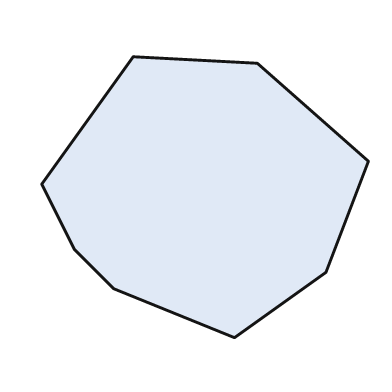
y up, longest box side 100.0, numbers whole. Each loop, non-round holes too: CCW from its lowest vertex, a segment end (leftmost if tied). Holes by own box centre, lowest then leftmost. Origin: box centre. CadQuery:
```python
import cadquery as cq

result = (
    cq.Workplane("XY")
    .moveTo(9.0, -43.0)
    .lineTo(37.0, -23.0)
    .lineTo(50.0, 11.0)
    .lineTo(16.0, 41.0)
    .lineTo(-22.0, 43.0)
    .lineTo(-50.0, 4.0)
    .lineTo(-40.0, -16.0)
    .lineTo(-28.0, -28.0)
    .close()
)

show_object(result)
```